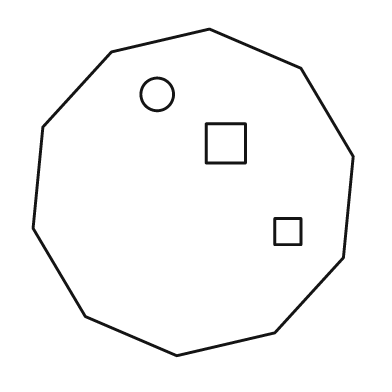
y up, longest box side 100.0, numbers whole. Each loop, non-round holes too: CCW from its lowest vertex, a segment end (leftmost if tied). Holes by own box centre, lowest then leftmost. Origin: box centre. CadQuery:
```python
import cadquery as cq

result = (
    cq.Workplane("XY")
    .moveTo(-5.0, -50.0)
    .lineTo(25.0, -43.0)
    .lineTo(46.0, -20.0)
    .lineTo(49.0, 11.0)
    .lineTo(33.0, 38.0)
    .lineTo(5.0, 50.0)
    .lineTo(-25.0, 43.0)
    .lineTo(-46.0, 20.0)
    .lineTo(-49.0, -11.0)
    .lineTo(-33.0, -38.0)
    .close()
    .moveTo(25.0, -16.0)
    .lineTo(33.0, -16.0)
    .lineTo(33.0, -8.0)
    .lineTo(25.0, -8.0)
    .close()
    .moveTo(4.0, 9.0)
    .lineTo(16.0, 9.0)
    .lineTo(16.0, 21.0)
    .lineTo(4.0, 21.0)
    .close()
    .moveTo(-11.0, 30.0)
    .circle(5.0)
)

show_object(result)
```